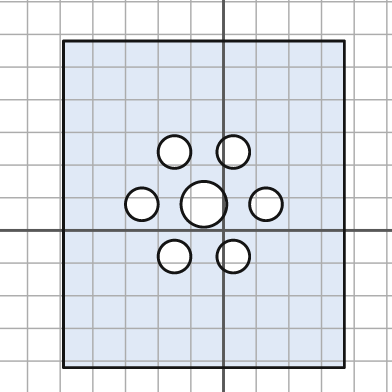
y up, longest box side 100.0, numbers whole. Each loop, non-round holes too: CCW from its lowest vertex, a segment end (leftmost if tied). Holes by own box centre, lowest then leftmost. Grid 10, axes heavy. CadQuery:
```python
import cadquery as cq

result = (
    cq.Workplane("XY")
    .moveTo(-49.0, -42.0)
    .lineTo(37.0, -42.0)
    .lineTo(37.0, 58.0)
    .lineTo(-49.0, 58.0)
    .close()
    .moveTo(-15.0, -8.0)
    .circle(5.0)
    .moveTo(3.0, -8.0)
    .circle(5.0)
    .moveTo(-25.0, 8.0)
    .circle(5.0)
    .moveTo(-6.0, 8.0)
    .circle(7.0)
    .moveTo(13.0, 8.0)
    .circle(5.0)
    .moveTo(-15.0, 24.0)
    .circle(5.0)
    .moveTo(3.0, 24.0)
    .circle(5.0)
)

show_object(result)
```